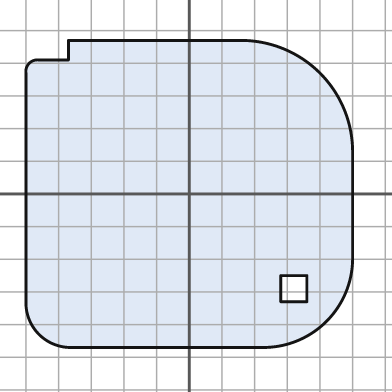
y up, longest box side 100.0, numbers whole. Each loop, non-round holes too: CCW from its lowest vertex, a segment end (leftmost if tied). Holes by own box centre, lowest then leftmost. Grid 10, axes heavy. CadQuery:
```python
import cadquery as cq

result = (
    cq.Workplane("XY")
    .moveTo(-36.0, -47.0)
    .lineTo(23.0, -47.0)
    .threePointArc((42.0, -39.0), (50.0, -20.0))
    .lineTo(50.0, 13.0)
    .threePointArc((40.0, 37.0), (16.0, 47.0))
    .lineTo(-37.0, 47.0)
    .lineTo(-37.0, 41.0)
    .lineTo(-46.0, 41.0)
    .threePointArc((-49.0, 40.0), (-50.0, 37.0))
    .lineTo(-50.0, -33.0)
    .threePointArc((-46.0, -43.0), (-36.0, -47.0))
    .close()
    .moveTo(28.0, -33.0)
    .lineTo(36.0, -33.0)
    .lineTo(36.0, -25.0)
    .lineTo(28.0, -25.0)
    .close()
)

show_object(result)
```